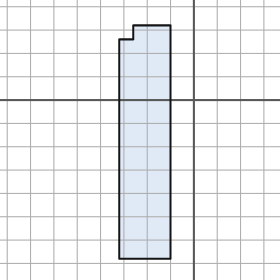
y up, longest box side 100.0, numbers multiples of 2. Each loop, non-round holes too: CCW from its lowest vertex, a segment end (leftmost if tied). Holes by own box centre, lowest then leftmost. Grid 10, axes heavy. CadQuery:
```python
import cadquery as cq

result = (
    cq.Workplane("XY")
    .moveTo(-32.0, -68.0)
    .lineTo(-10.0, -68.0)
    .lineTo(-10.0, 32.0)
    .lineTo(-26.0, 32.0)
    .lineTo(-26.0, 26.0)
    .lineTo(-32.0, 26.0)
    .close()
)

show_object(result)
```